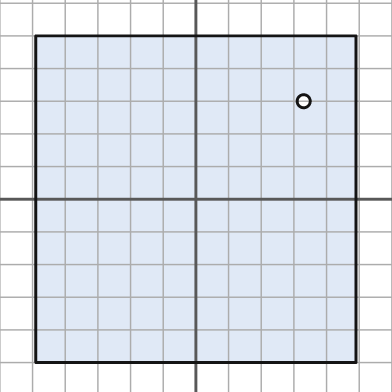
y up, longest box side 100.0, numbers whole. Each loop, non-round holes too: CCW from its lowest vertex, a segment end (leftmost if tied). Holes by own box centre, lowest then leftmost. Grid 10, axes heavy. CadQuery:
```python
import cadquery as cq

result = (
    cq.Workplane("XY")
    .moveTo(-49.0, -50.0)
    .lineTo(49.0, -50.0)
    .lineTo(49.0, 50.0)
    .lineTo(-49.0, 50.0)
    .close()
    .moveTo(33.0, 30.0)
    .circle(2.0)
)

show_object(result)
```